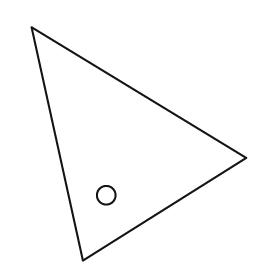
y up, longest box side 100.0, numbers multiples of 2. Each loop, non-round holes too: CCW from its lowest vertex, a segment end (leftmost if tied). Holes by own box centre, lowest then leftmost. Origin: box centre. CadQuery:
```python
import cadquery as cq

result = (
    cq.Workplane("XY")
    .moveTo(-24.0, -50.0)
    .lineTo(46.0, -6.0)
    .lineTo(-46.0, 50.0)
    .close()
    .moveTo(-14.0, -22.0)
    .circle(4.0)
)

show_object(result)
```